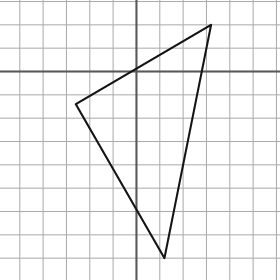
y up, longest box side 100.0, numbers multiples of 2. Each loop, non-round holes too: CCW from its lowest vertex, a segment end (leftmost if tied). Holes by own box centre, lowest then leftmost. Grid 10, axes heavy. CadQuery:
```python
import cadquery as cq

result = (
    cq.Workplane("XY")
    .moveTo(12.0, -80.0)
    .lineTo(32.0, 20.0)
    .lineTo(-26.0, -14.0)
    .close()
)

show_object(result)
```